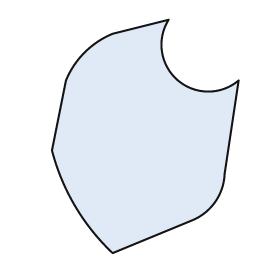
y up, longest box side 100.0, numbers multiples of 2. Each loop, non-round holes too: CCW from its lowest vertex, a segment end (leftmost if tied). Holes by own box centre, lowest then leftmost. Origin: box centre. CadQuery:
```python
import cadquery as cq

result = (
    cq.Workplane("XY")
    .moveTo(-14.0, -50.0)
    .lineTo(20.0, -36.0)
    .threePointArc((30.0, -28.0), (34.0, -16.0))
    .lineTo(40.0, 24.0)
    .threePointArc((14.0, 24.0), (10.0, 50.0))
    .lineTo(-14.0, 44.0)
    .threePointArc((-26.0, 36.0), (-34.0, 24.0))
    .lineTo(-40.0, -6.0)
    .threePointArc((-30.0, -30.0), (-14.0, -50.0))
    .close()
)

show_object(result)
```